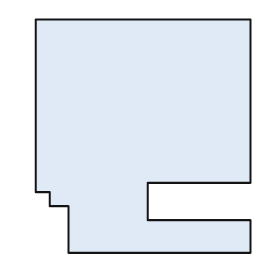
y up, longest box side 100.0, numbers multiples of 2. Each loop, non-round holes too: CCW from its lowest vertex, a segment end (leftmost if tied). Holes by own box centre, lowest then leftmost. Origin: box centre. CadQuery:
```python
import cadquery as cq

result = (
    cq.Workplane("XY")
    .moveTo(-32.0, -50.0)
    .lineTo(46.0, -50.0)
    .lineTo(46.0, -36.0)
    .lineTo(2.0, -36.0)
    .lineTo(2.0, -20.0)
    .lineTo(46.0, -20.0)
    .lineTo(46.0, 50.0)
    .lineTo(-46.0, 50.0)
    .lineTo(-46.0, -24.0)
    .lineTo(-40.0, -24.0)
    .lineTo(-40.0, -30.0)
    .lineTo(-32.0, -30.0)
    .close()
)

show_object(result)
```